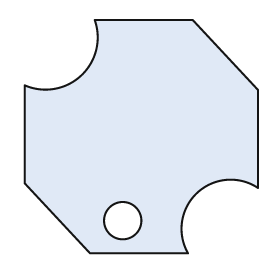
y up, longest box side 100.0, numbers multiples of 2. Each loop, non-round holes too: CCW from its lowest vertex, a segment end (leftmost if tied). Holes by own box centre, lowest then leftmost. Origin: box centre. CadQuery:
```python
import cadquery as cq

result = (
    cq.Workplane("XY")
    .moveTo(-22.0, -50.0)
    .lineTo(20.0, -50.0)
    .threePointArc((24.0, -24.0), (50.0, -22.0))
    .lineTo(50.0, 20.0)
    .lineTo(22.0, 50.0)
    .lineTo(-20.0, 50.0)
    .threePointArc((-26.0, 26.0), (-50.0, 22.0))
    .lineTo(-50.0, -20.0)
    .close()
    .moveTo(-8.0, -36.0)
    .circle(8.0)
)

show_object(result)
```